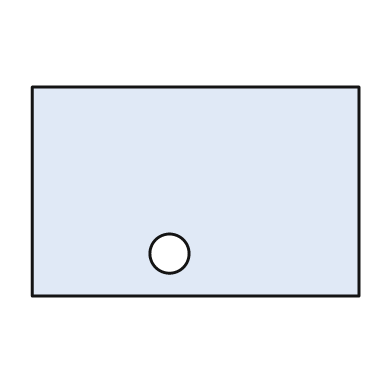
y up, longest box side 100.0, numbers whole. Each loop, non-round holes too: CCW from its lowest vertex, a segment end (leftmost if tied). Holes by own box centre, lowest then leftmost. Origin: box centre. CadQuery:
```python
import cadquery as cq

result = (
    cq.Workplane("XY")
    .moveTo(-50.0, -32.0)
    .lineTo(50.0, -32.0)
    .lineTo(50.0, 32.0)
    .lineTo(-50.0, 32.0)
    .close()
    .moveTo(-8.0, -19.0)
    .circle(6.0)
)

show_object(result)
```